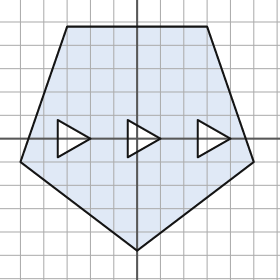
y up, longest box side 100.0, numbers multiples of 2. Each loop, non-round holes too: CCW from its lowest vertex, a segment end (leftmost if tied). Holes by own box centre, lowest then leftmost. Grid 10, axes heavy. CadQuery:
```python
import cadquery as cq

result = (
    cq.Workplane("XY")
    .moveTo(0.0, -48.0)
    .lineTo(50.0, -10.0)
    .lineTo(30.0, 48.0)
    .lineTo(-30.0, 48.0)
    .lineTo(-50.0, -10.0)
    .close()
    .moveTo(-34.0, -8.0)
    .lineTo(-20.0, 0.0)
    .lineTo(-34.0, 8.0)
    .close()
    .moveTo(-4.0, -8.0)
    .lineTo(10.0, 0.0)
    .lineTo(-4.0, 8.0)
    .close()
    .moveTo(26.0, -8.0)
    .lineTo(40.0, 0.0)
    .lineTo(26.0, 8.0)
    .close()
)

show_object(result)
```